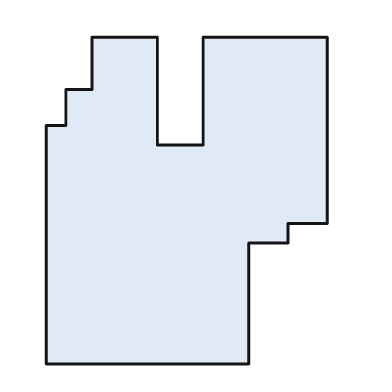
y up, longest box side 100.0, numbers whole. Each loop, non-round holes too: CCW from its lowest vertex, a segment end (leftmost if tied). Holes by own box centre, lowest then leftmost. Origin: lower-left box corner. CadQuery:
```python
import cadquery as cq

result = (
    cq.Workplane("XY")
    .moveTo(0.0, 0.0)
    .lineTo(62.0, 0.0)
    .lineTo(62.0, 37.0)
    .lineTo(74.0, 37.0)
    .lineTo(74.0, 43.0)
    .lineTo(86.0, 43.0)
    .lineTo(86.0, 100.0)
    .lineTo(48.0, 100.0)
    .lineTo(48.0, 67.0)
    .lineTo(34.0, 67.0)
    .lineTo(34.0, 100.0)
    .lineTo(14.0, 100.0)
    .lineTo(14.0, 84.0)
    .lineTo(6.0, 84.0)
    .lineTo(6.0, 73.0)
    .lineTo(0.0, 73.0)
    .close()
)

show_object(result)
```